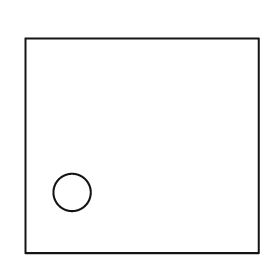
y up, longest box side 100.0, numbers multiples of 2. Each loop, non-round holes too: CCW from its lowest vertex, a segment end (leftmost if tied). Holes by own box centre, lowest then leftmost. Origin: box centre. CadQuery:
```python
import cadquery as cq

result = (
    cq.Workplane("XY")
    .moveTo(-50.0, -46.0)
    .lineTo(50.0, -46.0)
    .lineTo(50.0, 46.0)
    .lineTo(-50.0, 46.0)
    .close()
    .moveTo(-30.0, -20.0)
    .circle(8.0)
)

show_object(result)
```